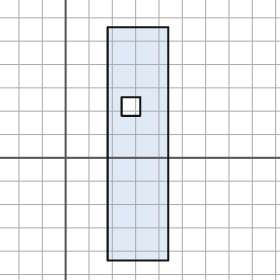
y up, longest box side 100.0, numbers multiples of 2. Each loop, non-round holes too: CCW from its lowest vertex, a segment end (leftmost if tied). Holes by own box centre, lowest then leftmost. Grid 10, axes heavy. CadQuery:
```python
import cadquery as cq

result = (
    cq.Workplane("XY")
    .moveTo(18.0, -44.0)
    .lineTo(44.0, -44.0)
    .lineTo(44.0, 56.0)
    .lineTo(18.0, 56.0)
    .close()
    .moveTo(24.0, 18.0)
    .lineTo(32.0, 18.0)
    .lineTo(32.0, 26.0)
    .lineTo(24.0, 26.0)
    .close()
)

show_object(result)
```